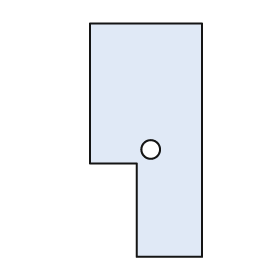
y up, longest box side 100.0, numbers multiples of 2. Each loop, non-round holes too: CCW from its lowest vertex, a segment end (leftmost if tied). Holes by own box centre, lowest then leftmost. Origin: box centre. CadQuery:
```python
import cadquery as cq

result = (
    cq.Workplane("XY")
    .moveTo(-4.0, -50.0)
    .lineTo(24.0, -50.0)
    .lineTo(24.0, 50.0)
    .lineTo(-24.0, 50.0)
    .lineTo(-24.0, -10.0)
    .lineTo(-4.0, -10.0)
    .close()
    .moveTo(2.0, -4.0)
    .circle(4.0)
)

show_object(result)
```